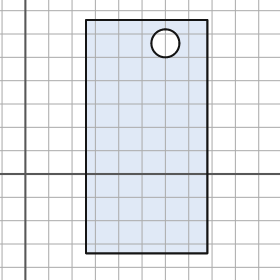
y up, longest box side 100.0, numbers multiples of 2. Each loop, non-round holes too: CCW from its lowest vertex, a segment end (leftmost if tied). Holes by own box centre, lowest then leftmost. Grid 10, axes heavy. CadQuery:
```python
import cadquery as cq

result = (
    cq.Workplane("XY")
    .moveTo(26.0, -34.0)
    .lineTo(78.0, -34.0)
    .lineTo(78.0, 66.0)
    .lineTo(26.0, 66.0)
    .close()
    .moveTo(60.0, 56.0)
    .circle(6.0)
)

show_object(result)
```